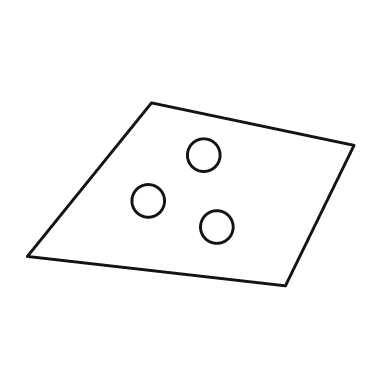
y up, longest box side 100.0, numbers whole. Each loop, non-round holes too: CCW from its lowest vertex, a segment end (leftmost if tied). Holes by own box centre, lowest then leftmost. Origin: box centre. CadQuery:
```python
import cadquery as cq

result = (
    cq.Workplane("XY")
    .moveTo(29.0, -28.0)
    .lineTo(50.0, 15.0)
    .lineTo(-12.0, 28.0)
    .lineTo(-50.0, -19.0)
    .close()
    .moveTo(8.0, -10.0)
    .circle(5.0)
    .moveTo(-13.0, -2.0)
    .circle(5.0)
    .moveTo(4.0, 12.0)
    .circle(5.0)
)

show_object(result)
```